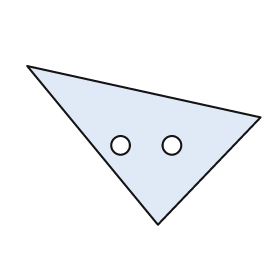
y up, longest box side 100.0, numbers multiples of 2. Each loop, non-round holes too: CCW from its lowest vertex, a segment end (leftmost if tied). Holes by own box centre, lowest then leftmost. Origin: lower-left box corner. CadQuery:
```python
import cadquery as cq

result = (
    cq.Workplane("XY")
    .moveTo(56.0, 0.0)
    .lineTo(100.0, 46.0)
    .lineTo(0.0, 68.0)
    .close()
    .moveTo(40.0, 34.0)
    .circle(4.0)
    .moveTo(62.0, 34.0)
    .circle(4.0)
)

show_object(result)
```